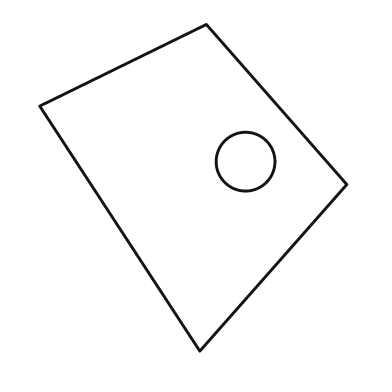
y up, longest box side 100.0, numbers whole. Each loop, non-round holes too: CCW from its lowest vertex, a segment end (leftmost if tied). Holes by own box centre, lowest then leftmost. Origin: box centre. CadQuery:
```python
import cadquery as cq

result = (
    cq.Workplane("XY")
    .moveTo(2.0, -50.0)
    .lineTo(47.0, 1.0)
    .lineTo(4.0, 50.0)
    .lineTo(-47.0, 25.0)
    .close()
    .moveTo(16.0, 8.0)
    .circle(9.0)
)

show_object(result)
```